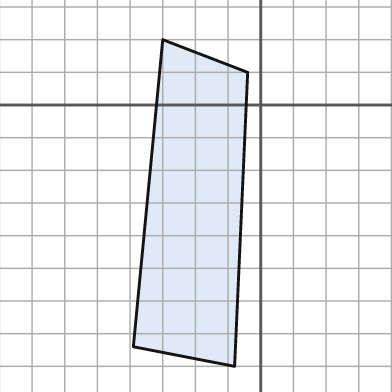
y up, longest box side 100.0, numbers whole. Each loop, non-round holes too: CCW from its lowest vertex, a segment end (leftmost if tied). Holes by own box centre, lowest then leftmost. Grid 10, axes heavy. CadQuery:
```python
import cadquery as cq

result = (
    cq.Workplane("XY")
    .moveTo(-8.0, -80.0)
    .lineTo(-4.0, 10.0)
    .lineTo(-30.0, 20.0)
    .lineTo(-39.0, -74.0)
    .close()
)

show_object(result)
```